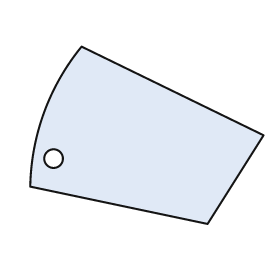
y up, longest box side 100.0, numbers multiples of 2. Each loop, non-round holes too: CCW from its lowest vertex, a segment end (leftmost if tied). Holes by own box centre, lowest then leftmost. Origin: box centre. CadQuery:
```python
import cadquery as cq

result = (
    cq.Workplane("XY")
    .moveTo(26.0, -38.0)
    .lineTo(50.0, 0.0)
    .lineTo(-28.0, 38.0)
    .threePointArc((-44.0, 10.0), (-50.0, -22.0))
    .close()
    .moveTo(-40.0, -10.0)
    .circle(4.0)
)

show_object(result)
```